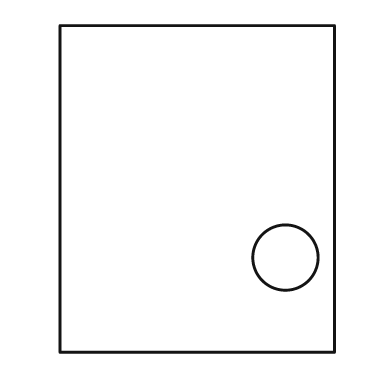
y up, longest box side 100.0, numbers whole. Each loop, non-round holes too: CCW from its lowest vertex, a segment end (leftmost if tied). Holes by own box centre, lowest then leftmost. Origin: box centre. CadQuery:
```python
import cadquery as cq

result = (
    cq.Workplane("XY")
    .moveTo(-42.0, -50.0)
    .lineTo(42.0, -50.0)
    .lineTo(42.0, 50.0)
    .lineTo(-42.0, 50.0)
    .close()
    .moveTo(27.0, -21.0)
    .circle(10.0)
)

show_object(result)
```